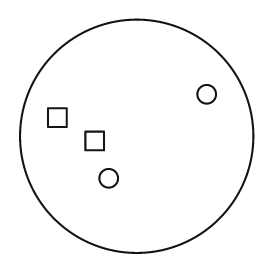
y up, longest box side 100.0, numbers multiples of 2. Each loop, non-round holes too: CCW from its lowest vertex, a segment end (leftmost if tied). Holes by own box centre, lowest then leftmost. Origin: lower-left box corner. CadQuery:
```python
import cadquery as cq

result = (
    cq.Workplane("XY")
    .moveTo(50.0, 50.0)
    .circle(50.0)
    .moveTo(38.0, 32.0)
    .circle(4.0)
    .moveTo(28.0, 44.0)
    .lineTo(36.0, 44.0)
    .lineTo(36.0, 52.0)
    .lineTo(28.0, 52.0)
    .close()
    .moveTo(12.0, 54.0)
    .lineTo(20.0, 54.0)
    .lineTo(20.0, 62.0)
    .lineTo(12.0, 62.0)
    .close()
    .moveTo(80.0, 68.0)
    .circle(4.0)
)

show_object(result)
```